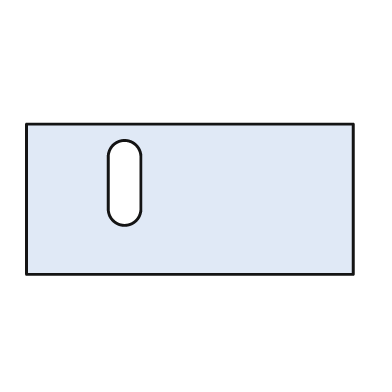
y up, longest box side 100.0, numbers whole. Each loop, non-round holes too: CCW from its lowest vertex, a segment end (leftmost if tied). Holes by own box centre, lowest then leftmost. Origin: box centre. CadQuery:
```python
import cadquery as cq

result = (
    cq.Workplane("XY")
    .moveTo(-50.0, -23.0)
    .lineTo(50.0, -23.0)
    .lineTo(50.0, 23.0)
    .lineTo(-50.0, 23.0)
    .close()
    .moveTo(-25.0, -3.0)
    .threePointArc((-20.0, -8.0), (-15.0, -3.0))
    .lineTo(-15.0, 13.0)
    .threePointArc((-20.0, 18.0), (-25.0, 13.0))
    .close()
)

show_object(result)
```